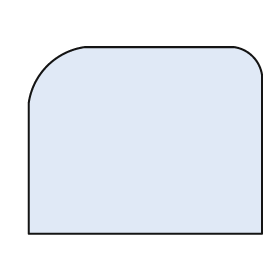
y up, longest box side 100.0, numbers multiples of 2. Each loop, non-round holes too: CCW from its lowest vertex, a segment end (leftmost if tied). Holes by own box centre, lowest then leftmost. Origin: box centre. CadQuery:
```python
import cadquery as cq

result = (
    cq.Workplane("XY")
    .moveTo(-50.0, -40.0)
    .lineTo(50.0, -40.0)
    .lineTo(50.0, 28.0)
    .threePointArc((46.0, 36.0), (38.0, 40.0))
    .lineTo(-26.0, 40.0)
    .threePointArc((-42.0, 32.0), (-50.0, 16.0))
    .close()
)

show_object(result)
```